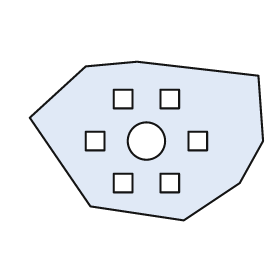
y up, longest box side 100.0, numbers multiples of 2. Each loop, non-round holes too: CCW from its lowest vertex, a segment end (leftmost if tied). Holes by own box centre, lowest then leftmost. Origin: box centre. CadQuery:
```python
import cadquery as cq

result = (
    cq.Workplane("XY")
    .moveTo(16.0, -34.0)
    .lineTo(40.0, -18.0)
    .lineTo(50.0, 0.0)
    .lineTo(48.0, 28.0)
    .lineTo(-4.0, 34.0)
    .lineTo(-26.0, 32.0)
    .lineTo(-50.0, 10.0)
    .lineTo(-24.0, -28.0)
    .close()
    .moveTo(-14.0, -22.0)
    .lineTo(-6.0, -22.0)
    .lineTo(-6.0, -14.0)
    .lineTo(-14.0, -14.0)
    .close()
    .moveTo(6.0, -22.0)
    .lineTo(14.0, -22.0)
    .lineTo(14.0, -14.0)
    .lineTo(6.0, -14.0)
    .close()
    .moveTo(-26.0, -4.0)
    .lineTo(-18.0, -4.0)
    .lineTo(-18.0, 4.0)
    .lineTo(-26.0, 4.0)
    .close()
    .moveTo(0.0, 0.0)
    .circle(8.0)
    .moveTo(18.0, -4.0)
    .lineTo(26.0, -4.0)
    .lineTo(26.0, 4.0)
    .lineTo(18.0, 4.0)
    .close()
    .moveTo(-14.0, 14.0)
    .lineTo(-6.0, 14.0)
    .lineTo(-6.0, 22.0)
    .lineTo(-14.0, 22.0)
    .close()
    .moveTo(6.0, 14.0)
    .lineTo(14.0, 14.0)
    .lineTo(14.0, 22.0)
    .lineTo(6.0, 22.0)
    .close()
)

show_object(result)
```